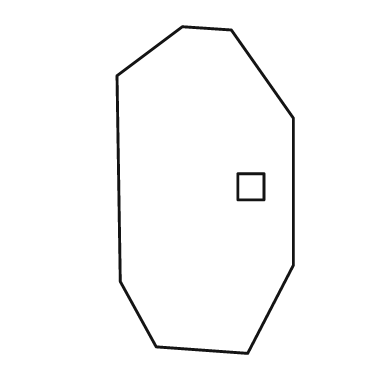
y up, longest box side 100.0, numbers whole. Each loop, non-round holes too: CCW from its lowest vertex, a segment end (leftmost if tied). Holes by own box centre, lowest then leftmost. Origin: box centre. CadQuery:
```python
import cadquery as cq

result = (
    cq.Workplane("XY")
    .moveTo(13.0, -50.0)
    .lineTo(27.0, -23.0)
    .lineTo(27.0, 22.0)
    .lineTo(8.0, 49.0)
    .lineTo(-7.0, 50.0)
    .lineTo(-27.0, 35.0)
    .lineTo(-26.0, -28.0)
    .lineTo(-15.0, -48.0)
    .close()
    .moveTo(10.0, -3.0)
    .lineTo(18.0, -3.0)
    .lineTo(18.0, 5.0)
    .lineTo(10.0, 5.0)
    .close()
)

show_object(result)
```